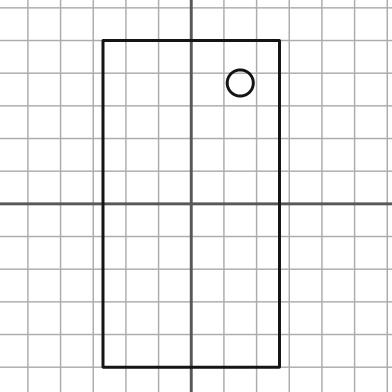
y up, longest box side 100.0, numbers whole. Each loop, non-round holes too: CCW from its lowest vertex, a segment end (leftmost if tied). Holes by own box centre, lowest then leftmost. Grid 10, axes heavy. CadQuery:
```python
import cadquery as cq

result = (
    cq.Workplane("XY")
    .moveTo(-27.0, -50.0)
    .lineTo(27.0, -50.0)
    .lineTo(27.0, 50.0)
    .lineTo(-27.0, 50.0)
    .close()
    .moveTo(15.0, 37.0)
    .circle(4.0)
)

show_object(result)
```